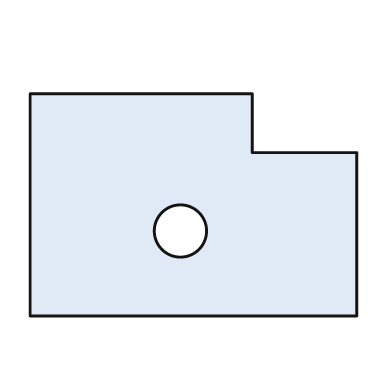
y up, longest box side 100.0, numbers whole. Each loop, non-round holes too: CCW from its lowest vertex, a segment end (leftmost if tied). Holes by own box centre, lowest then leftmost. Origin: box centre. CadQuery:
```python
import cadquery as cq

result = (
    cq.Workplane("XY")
    .moveTo(-50.0, -34.0)
    .lineTo(50.0, -34.0)
    .lineTo(50.0, 16.0)
    .lineTo(18.0, 16.0)
    .lineTo(18.0, 34.0)
    .lineTo(-50.0, 34.0)
    .close()
    .moveTo(-4.0, -8.0)
    .circle(8.0)
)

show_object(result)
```